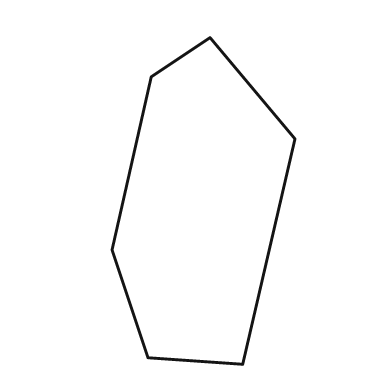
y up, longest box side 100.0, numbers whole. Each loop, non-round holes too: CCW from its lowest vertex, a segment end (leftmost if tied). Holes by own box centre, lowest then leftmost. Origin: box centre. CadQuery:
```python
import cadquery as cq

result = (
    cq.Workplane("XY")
    .moveTo(12.0, -50.0)
    .lineTo(28.0, 19.0)
    .lineTo(2.0, 50.0)
    .lineTo(-16.0, 38.0)
    .lineTo(-28.0, -15.0)
    .lineTo(-17.0, -48.0)
    .close()
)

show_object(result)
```